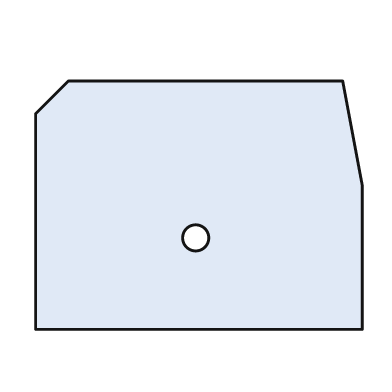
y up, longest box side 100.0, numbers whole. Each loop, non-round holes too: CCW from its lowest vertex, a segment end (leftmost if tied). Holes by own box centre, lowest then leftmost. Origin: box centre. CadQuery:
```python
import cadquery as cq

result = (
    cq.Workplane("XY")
    .moveTo(-50.0, -38.0)
    .lineTo(50.0, -38.0)
    .lineTo(50.0, 6.0)
    .lineTo(44.0, 38.0)
    .lineTo(-40.0, 38.0)
    .lineTo(-50.0, 28.0)
    .close()
    .moveTo(-1.0, -10.0)
    .circle(4.0)
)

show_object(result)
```